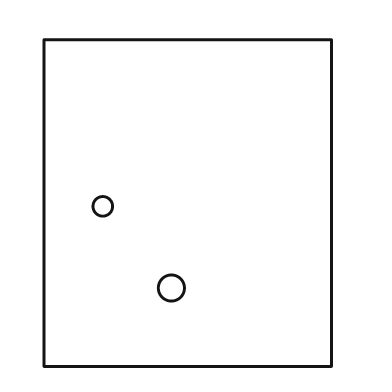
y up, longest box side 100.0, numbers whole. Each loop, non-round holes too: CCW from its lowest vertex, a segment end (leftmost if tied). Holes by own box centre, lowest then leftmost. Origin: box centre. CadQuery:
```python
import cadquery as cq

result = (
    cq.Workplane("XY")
    .moveTo(-44.0, -50.0)
    .lineTo(44.0, -50.0)
    .lineTo(44.0, 50.0)
    .lineTo(-44.0, 50.0)
    .close()
    .moveTo(-5.0, -26.0)
    .circle(4.0)
    .moveTo(-26.0, -1.0)
    .circle(3.0)
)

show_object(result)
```